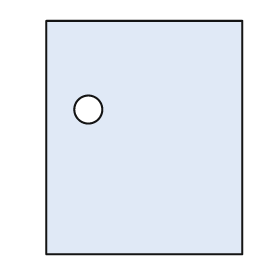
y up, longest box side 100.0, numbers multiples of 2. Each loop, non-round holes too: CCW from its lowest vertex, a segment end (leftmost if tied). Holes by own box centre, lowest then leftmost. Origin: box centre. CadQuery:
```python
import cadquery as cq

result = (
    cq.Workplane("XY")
    .moveTo(-42.0, -50.0)
    .lineTo(42.0, -50.0)
    .lineTo(42.0, 50.0)
    .lineTo(-42.0, 50.0)
    .close()
    .moveTo(-24.0, 12.0)
    .circle(6.0)
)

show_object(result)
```